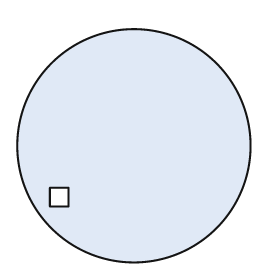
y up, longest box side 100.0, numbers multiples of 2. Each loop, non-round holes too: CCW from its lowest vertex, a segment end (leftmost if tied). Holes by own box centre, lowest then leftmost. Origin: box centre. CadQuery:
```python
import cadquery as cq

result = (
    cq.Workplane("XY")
    .moveTo(0.0, 0.0)
    .circle(50.0)
    .moveTo(-36.0, -26.0)
    .lineTo(-28.0, -26.0)
    .lineTo(-28.0, -18.0)
    .lineTo(-36.0, -18.0)
    .close()
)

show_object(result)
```